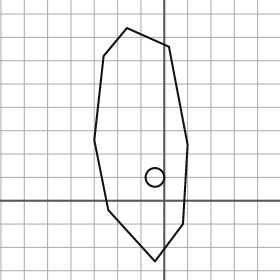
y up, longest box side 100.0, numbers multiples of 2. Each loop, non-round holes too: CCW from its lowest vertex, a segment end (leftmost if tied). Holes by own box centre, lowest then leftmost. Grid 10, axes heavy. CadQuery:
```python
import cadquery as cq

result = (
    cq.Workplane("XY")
    .moveTo(-4.0, -26.0)
    .lineTo(8.0, -10.0)
    .lineTo(10.0, 24.0)
    .lineTo(2.0, 66.0)
    .lineTo(-16.0, 74.0)
    .lineTo(-26.0, 62.0)
    .lineTo(-30.0, 26.0)
    .lineTo(-24.0, -4.0)
    .close()
    .moveTo(-4.0, 10.0)
    .circle(4.0)
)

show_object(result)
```